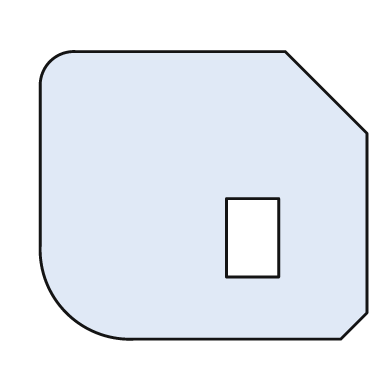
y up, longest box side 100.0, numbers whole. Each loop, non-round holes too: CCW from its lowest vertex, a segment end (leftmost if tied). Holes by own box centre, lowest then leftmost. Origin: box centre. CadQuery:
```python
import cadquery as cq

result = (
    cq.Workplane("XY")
    .moveTo(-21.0, -44.0)
    .lineTo(42.0, -44.0)
    .lineTo(50.0, -36.0)
    .lineTo(50.0, 19.0)
    .lineTo(25.0, 44.0)
    .lineTo(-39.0, 44.0)
    .threePointArc((-47.0, 41.0), (-50.0, 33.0))
    .lineTo(-50.0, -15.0)
    .threePointArc((-42.0, -36.0), (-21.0, -44.0))
    .close()
    .moveTo(7.0, -25.0)
    .lineTo(23.0, -25.0)
    .lineTo(23.0, -1.0)
    .lineTo(7.0, -1.0)
    .close()
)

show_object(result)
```